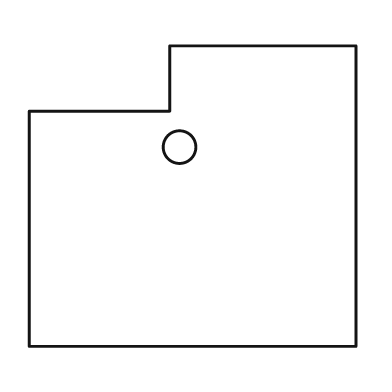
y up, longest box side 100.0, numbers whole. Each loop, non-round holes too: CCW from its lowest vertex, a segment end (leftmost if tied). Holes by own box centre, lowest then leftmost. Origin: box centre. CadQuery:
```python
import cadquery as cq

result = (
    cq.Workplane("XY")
    .moveTo(-50.0, -46.0)
    .lineTo(50.0, -46.0)
    .lineTo(50.0, 46.0)
    .lineTo(-7.0, 46.0)
    .lineTo(-7.0, 26.0)
    .lineTo(-50.0, 26.0)
    .close()
    .moveTo(-4.0, 15.0)
    .circle(5.0)
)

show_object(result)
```